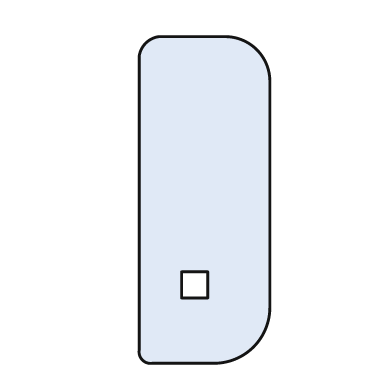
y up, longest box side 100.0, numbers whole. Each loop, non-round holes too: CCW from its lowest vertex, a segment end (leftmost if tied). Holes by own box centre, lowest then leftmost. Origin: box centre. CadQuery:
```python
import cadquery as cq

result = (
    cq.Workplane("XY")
    .moveTo(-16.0, -50.0)
    .lineTo(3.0, -50.0)
    .threePointArc((15.0, -45.0), (20.0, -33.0))
    .lineTo(20.0, 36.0)
    .threePointArc((16.0, 46.0), (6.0, 50.0))
    .lineTo(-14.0, 50.0)
    .threePointArc((-18.0, 48.0), (-20.0, 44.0))
    .lineTo(-20.0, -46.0)
    .threePointArc((-19.0, -49.0), (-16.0, -50.0))
    .close()
    .moveTo(-7.0, -30.0)
    .lineTo(1.0, -30.0)
    .lineTo(1.0, -22.0)
    .lineTo(-7.0, -22.0)
    .close()
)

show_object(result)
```